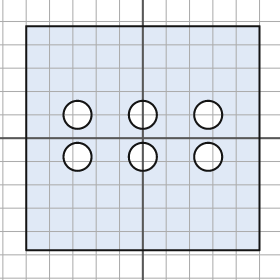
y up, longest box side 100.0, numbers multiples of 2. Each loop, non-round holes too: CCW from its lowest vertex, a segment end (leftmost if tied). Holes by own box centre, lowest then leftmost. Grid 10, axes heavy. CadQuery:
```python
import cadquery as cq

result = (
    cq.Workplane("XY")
    .moveTo(-50.0, -48.0)
    .lineTo(50.0, -48.0)
    .lineTo(50.0, 48.0)
    .lineTo(-50.0, 48.0)
    .close()
    .moveTo(-28.0, -8.0)
    .circle(6.0)
    .moveTo(0.0, -8.0)
    .circle(6.0)
    .moveTo(28.0, -8.0)
    .circle(6.0)
    .moveTo(-28.0, 10.0)
    .circle(6.0)
    .moveTo(0.0, 10.0)
    .circle(6.0)
    .moveTo(28.0, 10.0)
    .circle(6.0)
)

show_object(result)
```